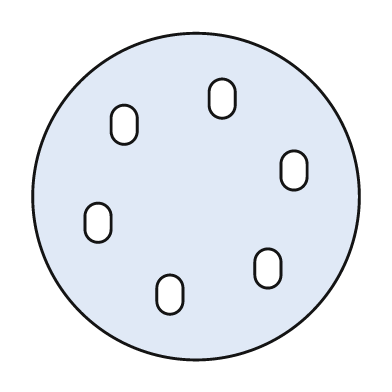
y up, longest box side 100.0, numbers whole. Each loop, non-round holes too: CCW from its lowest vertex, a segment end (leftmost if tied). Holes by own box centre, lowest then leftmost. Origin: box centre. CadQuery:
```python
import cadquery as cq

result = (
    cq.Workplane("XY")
    .moveTo(0.0, 0.0)
    .circle(50.0)
    .moveTo(-12.0, -32.0)
    .threePointArc((-8.0, -36.0), (-4.0, -32.0))
    .lineTo(-4.0, -28.0)
    .threePointArc((-8.0, -24.0), (-12.0, -28.0))
    .close()
    .moveTo(18.0, -24.0)
    .threePointArc((22.0, -28.0), (26.0, -24.0))
    .lineTo(26.0, -20.0)
    .threePointArc((22.0, -16.0), (18.0, -20.0))
    .close()
    .moveTo(-34.0, -10.0)
    .threePointArc((-30.0, -14.0), (-26.0, -10.0))
    .lineTo(-26.0, -6.0)
    .threePointArc((-30.0, -2.0), (-34.0, -6.0))
    .close()
    .moveTo(26.0, 6.0)
    .threePointArc((30.0, 2.0), (34.0, 6.0))
    .lineTo(34.0, 10.0)
    .threePointArc((30.0, 14.0), (26.0, 10.0))
    .close()
    .moveTo(-26.0, 20.0)
    .threePointArc((-22.0, 16.0), (-18.0, 20.0))
    .lineTo(-18.0, 24.0)
    .threePointArc((-22.0, 28.0), (-26.0, 24.0))
    .close()
    .moveTo(4.0, 28.0)
    .threePointArc((8.0, 24.0), (12.0, 28.0))
    .lineTo(12.0, 32.0)
    .threePointArc((8.0, 36.0), (4.0, 32.0))
    .close()
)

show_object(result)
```